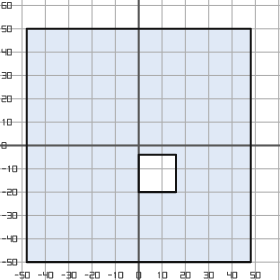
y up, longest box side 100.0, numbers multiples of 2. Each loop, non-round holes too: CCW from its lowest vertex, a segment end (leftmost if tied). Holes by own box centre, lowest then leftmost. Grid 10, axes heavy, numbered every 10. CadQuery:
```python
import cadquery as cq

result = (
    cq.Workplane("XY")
    .moveTo(-48.0, -50.0)
    .lineTo(48.0, -50.0)
    .lineTo(48.0, 50.0)
    .lineTo(-48.0, 50.0)
    .close()
    .moveTo(0.0, -20.0)
    .lineTo(16.0, -20.0)
    .lineTo(16.0, -4.0)
    .lineTo(0.0, -4.0)
    .close()
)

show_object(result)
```